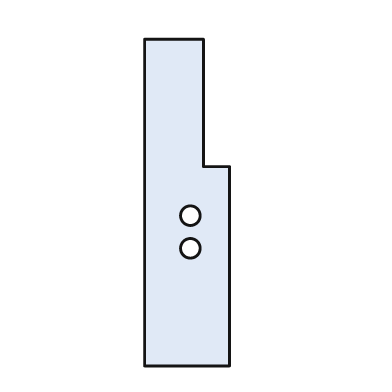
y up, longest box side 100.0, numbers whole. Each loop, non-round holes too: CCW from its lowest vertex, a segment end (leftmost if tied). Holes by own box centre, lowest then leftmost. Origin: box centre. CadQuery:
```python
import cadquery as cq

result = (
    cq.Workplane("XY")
    .moveTo(-13.0, -50.0)
    .lineTo(13.0, -50.0)
    .lineTo(13.0, 11.0)
    .lineTo(5.0, 11.0)
    .lineTo(5.0, 50.0)
    .lineTo(-13.0, 50.0)
    .close()
    .moveTo(1.0, -14.0)
    .circle(3.0)
    .moveTo(1.0, -4.0)
    .circle(3.0)
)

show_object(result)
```